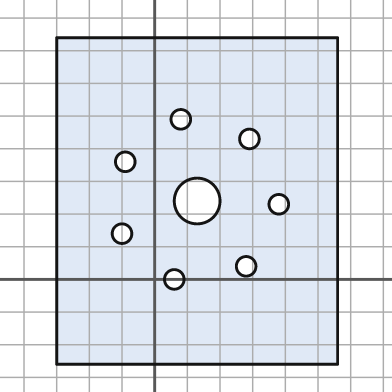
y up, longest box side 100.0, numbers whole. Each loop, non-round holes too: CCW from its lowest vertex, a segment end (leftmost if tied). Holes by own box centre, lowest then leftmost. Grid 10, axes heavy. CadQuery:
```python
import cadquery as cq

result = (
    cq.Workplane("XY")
    .moveTo(-30.0, -26.0)
    .lineTo(56.0, -26.0)
    .lineTo(56.0, 74.0)
    .lineTo(-30.0, 74.0)
    .close()
    .moveTo(6.0, 0.0)
    .circle(3.0)
    .moveTo(28.0, 4.0)
    .circle(3.0)
    .moveTo(-10.0, 14.0)
    .circle(3.0)
    .moveTo(38.0, 23.0)
    .circle(3.0)
    .moveTo(13.0, 24.0)
    .circle(7.0)
    .moveTo(-9.0, 36.0)
    .circle(3.0)
    .moveTo(29.0, 43.0)
    .circle(3.0)
    .moveTo(8.0, 49.0)
    .circle(3.0)
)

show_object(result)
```